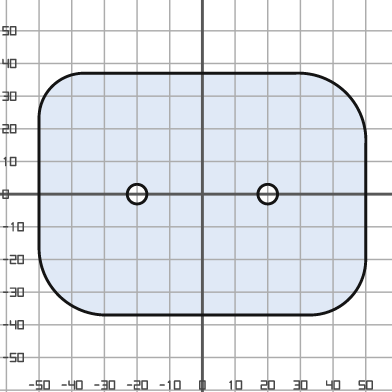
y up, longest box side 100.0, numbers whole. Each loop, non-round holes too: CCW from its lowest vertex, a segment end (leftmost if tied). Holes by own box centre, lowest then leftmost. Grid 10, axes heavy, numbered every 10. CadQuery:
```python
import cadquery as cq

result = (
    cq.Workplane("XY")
    .moveTo(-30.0, -37.0)
    .lineTo(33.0, -37.0)
    .threePointArc((45.0, -32.0), (50.0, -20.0))
    .lineTo(50.0, 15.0)
    .threePointArc((44.0, 31.0), (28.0, 37.0))
    .lineTo(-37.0, 37.0)
    .threePointArc((-46.0, 33.0), (-50.0, 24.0))
    .lineTo(-50.0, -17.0)
    .threePointArc((-44.0, -31.0), (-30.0, -37.0))
    .close()
    .moveTo(-20.0, 0.0)
    .circle(3.0)
    .moveTo(20.0, 0.0)
    .circle(3.0)
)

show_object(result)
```